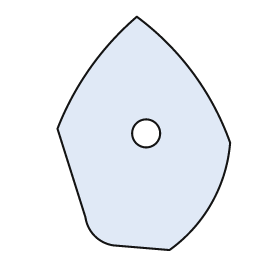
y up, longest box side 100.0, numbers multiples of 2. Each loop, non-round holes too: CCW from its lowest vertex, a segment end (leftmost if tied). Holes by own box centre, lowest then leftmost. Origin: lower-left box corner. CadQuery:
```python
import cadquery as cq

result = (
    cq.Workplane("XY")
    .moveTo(48.0, 0.0)
    .threePointArc((66.0, 20.0), (74.0, 46.0))
    .threePointArc((58.0, 76.0), (34.0, 100.0))
    .threePointArc((14.0, 78.0), (0.0, 52.0))
    .lineTo(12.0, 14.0)
    .threePointArc((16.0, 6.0), (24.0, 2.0))
    .close()
    .moveTo(38.0, 50.0)
    .circle(6.0)
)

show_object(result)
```